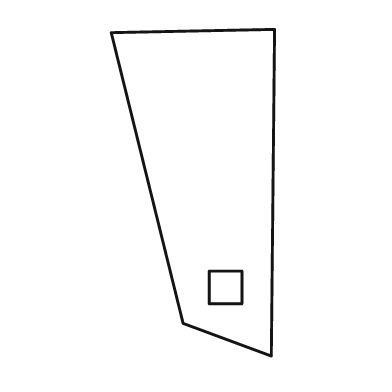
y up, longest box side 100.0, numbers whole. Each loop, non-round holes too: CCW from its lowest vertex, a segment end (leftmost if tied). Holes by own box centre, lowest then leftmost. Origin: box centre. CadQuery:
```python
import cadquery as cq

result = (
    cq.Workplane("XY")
    .moveTo(24.0, -50.0)
    .lineTo(25.0, 50.0)
    .lineTo(-25.0, 49.0)
    .lineTo(-3.0, -40.0)
    .close()
    .moveTo(5.0, -34.0)
    .lineTo(15.0, -34.0)
    .lineTo(15.0, -24.0)
    .lineTo(5.0, -24.0)
    .close()
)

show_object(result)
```